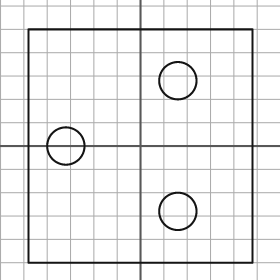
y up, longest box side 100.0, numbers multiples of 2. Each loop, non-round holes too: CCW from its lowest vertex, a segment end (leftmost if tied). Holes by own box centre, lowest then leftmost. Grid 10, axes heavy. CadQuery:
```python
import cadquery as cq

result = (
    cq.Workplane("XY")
    .moveTo(-48.0, -50.0)
    .lineTo(48.0, -50.0)
    .lineTo(48.0, 50.0)
    .lineTo(-48.0, 50.0)
    .close()
    .moveTo(16.0, -28.0)
    .circle(8.0)
    .moveTo(-32.0, 0.0)
    .circle(8.0)
    .moveTo(16.0, 28.0)
    .circle(8.0)
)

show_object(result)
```